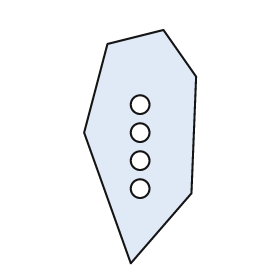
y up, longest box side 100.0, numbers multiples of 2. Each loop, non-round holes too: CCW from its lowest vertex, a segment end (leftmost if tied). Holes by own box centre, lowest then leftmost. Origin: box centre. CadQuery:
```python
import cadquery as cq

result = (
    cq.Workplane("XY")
    .moveTo(-4.0, -50.0)
    .lineTo(22.0, -20.0)
    .lineTo(24.0, 30.0)
    .lineTo(10.0, 50.0)
    .lineTo(-14.0, 44.0)
    .lineTo(-24.0, 6.0)
    .close()
    .moveTo(0.0, -18.0)
    .circle(4.0)
    .moveTo(0.0, -6.0)
    .circle(4.0)
    .moveTo(0.0, 6.0)
    .circle(4.0)
    .moveTo(0.0, 18.0)
    .circle(4.0)
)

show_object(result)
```